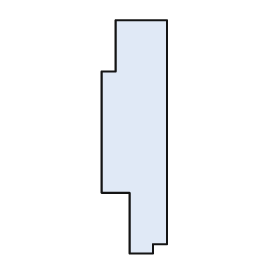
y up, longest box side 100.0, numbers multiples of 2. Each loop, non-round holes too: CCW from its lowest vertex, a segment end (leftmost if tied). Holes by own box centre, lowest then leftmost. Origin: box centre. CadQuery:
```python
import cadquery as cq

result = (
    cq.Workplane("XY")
    .moveTo(-2.0, -50.0)
    .lineTo(8.0, -50.0)
    .lineTo(8.0, -46.0)
    .lineTo(14.0, -46.0)
    .lineTo(14.0, 50.0)
    .lineTo(-8.0, 50.0)
    .lineTo(-8.0, 28.0)
    .lineTo(-14.0, 28.0)
    .lineTo(-14.0, -24.0)
    .lineTo(-2.0, -24.0)
    .close()
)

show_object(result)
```